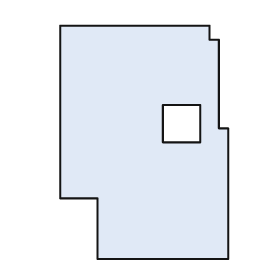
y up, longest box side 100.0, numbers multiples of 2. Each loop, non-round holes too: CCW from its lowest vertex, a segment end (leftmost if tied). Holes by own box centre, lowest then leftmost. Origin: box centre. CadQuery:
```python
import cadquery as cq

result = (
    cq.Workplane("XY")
    .moveTo(-20.0, -50.0)
    .lineTo(36.0, -50.0)
    .lineTo(36.0, 6.0)
    .lineTo(32.0, 6.0)
    .lineTo(32.0, 44.0)
    .lineTo(28.0, 44.0)
    .lineTo(28.0, 50.0)
    .lineTo(-36.0, 50.0)
    .lineTo(-36.0, -24.0)
    .lineTo(-20.0, -24.0)
    .close()
    .moveTo(8.0, 0.0)
    .lineTo(24.0, 0.0)
    .lineTo(24.0, 16.0)
    .lineTo(8.0, 16.0)
    .close()
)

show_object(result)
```